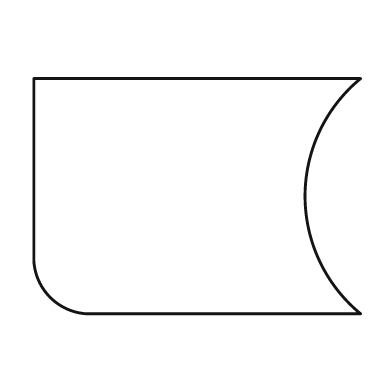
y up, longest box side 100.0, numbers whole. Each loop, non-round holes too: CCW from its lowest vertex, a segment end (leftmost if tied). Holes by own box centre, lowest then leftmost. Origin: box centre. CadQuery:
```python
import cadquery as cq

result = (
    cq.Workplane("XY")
    .moveTo(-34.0, -36.0)
    .lineTo(50.0, -36.0)
    .threePointArc((33.0, 0.0), (50.0, 36.0))
    .lineTo(-50.0, 36.0)
    .lineTo(-50.0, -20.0)
    .threePointArc((-45.0, -31.0), (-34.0, -36.0))
    .close()
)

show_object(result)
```